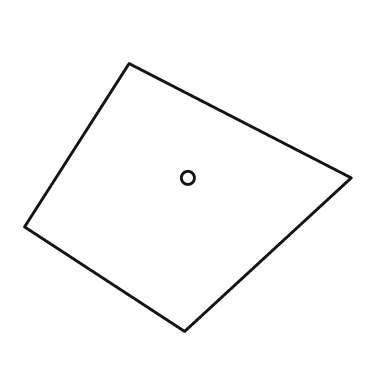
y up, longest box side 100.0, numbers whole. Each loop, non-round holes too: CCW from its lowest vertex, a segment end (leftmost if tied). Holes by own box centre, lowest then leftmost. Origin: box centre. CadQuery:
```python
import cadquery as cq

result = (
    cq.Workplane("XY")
    .moveTo(-1.0, -41.0)
    .lineTo(50.0, 6.0)
    .lineTo(-18.0, 41.0)
    .lineTo(-50.0, -9.0)
    .close()
    .moveTo(0.0, 6.0)
    .circle(2.0)
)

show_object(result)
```